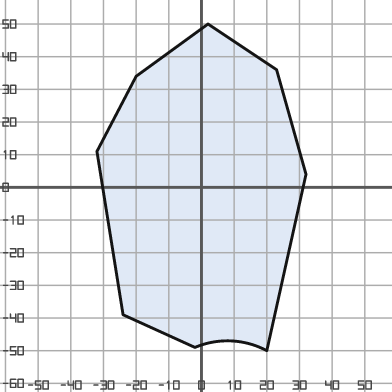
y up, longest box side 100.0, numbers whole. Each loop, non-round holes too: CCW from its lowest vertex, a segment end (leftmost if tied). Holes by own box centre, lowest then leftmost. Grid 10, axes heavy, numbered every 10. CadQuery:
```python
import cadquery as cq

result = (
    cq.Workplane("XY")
    .moveTo(20.0, -50.0)
    .lineTo(32.0, 4.0)
    .lineTo(23.0, 36.0)
    .lineTo(2.0, 50.0)
    .lineTo(-20.0, 34.0)
    .lineTo(-32.0, 11.0)
    .lineTo(-24.0, -39.0)
    .lineTo(-2.0, -49.0)
    .threePointArc((9.0, -47.0), (20.0, -50.0))
    .close()
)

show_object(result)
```